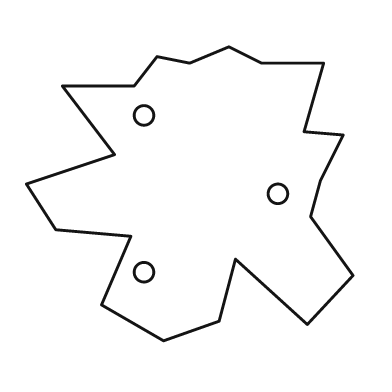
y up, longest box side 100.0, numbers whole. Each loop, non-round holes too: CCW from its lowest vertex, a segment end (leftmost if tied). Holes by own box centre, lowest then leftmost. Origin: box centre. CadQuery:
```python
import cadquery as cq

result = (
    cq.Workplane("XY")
    .moveTo(-8.0, -45.0)
    .lineTo(9.0, -39.0)
    .lineTo(14.0, -20.0)
    .lineTo(36.0, -40.0)
    .lineTo(50.0, -25.0)
    .lineTo(37.0, -7.0)
    .lineTo(40.0, 4.0)
    .lineTo(47.0, 18.0)
    .lineTo(35.0, 19.0)
    .lineTo(41.0, 40.0)
    .lineTo(22.0, 40.0)
    .lineTo(12.0, 45.0)
    .lineTo(0.0, 40.0)
    .lineTo(-10.0, 42.0)
    .lineTo(-17.0, 33.0)
    .lineTo(-39.0, 33.0)
    .lineTo(-23.0, 12.0)
    .lineTo(-50.0, 3.0)
    .lineTo(-41.0, -11.0)
    .lineTo(-18.0, -13.0)
    .lineTo(-27.0, -34.0)
    .close()
    .moveTo(-14.0, -24.0)
    .circle(3.0)
    .moveTo(27.0, 0.0)
    .circle(3.0)
    .moveTo(-14.0, 24.0)
    .circle(3.0)
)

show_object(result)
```